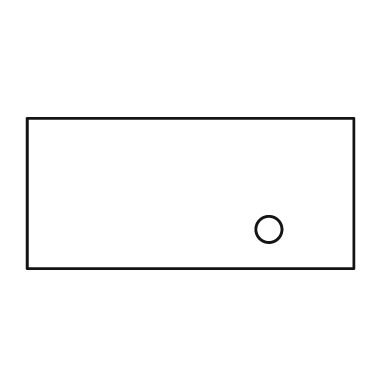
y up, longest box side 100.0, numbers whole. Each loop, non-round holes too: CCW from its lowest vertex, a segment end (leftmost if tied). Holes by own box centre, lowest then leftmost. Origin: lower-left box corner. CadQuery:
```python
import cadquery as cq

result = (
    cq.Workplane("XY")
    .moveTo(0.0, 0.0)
    .lineTo(100.0, 0.0)
    .lineTo(100.0, 46.0)
    .lineTo(0.0, 46.0)
    .close()
    .moveTo(74.0, 12.0)
    .circle(4.0)
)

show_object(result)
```